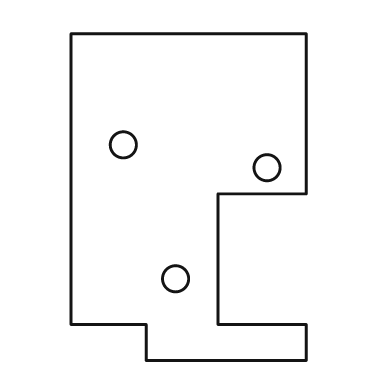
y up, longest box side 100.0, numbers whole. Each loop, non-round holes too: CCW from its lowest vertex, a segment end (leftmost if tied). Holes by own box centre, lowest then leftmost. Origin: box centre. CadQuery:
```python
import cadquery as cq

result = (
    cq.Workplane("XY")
    .moveTo(-13.0, -50.0)
    .lineTo(36.0, -50.0)
    .lineTo(36.0, -39.0)
    .lineTo(9.0, -39.0)
    .lineTo(9.0, 1.0)
    .lineTo(36.0, 1.0)
    .lineTo(36.0, 50.0)
    .lineTo(-36.0, 50.0)
    .lineTo(-36.0, -39.0)
    .lineTo(-13.0, -39.0)
    .close()
    .moveTo(-4.0, -25.0)
    .circle(4.0)
    .moveTo(24.0, 9.0)
    .circle(4.0)
    .moveTo(-20.0, 16.0)
    .circle(4.0)
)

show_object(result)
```